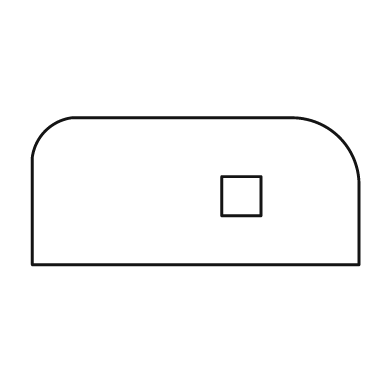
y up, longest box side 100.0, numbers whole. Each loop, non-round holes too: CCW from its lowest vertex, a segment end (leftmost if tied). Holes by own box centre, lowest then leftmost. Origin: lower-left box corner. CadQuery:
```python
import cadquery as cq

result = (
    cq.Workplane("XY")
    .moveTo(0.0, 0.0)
    .lineTo(100.0, 0.0)
    .lineTo(100.0, 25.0)
    .threePointArc((94.0, 39.0), (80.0, 45.0))
    .lineTo(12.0, 45.0)
    .threePointArc((4.0, 41.0), (0.0, 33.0))
    .close()
    .moveTo(58.0, 15.0)
    .lineTo(70.0, 15.0)
    .lineTo(70.0, 27.0)
    .lineTo(58.0, 27.0)
    .close()
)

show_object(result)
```